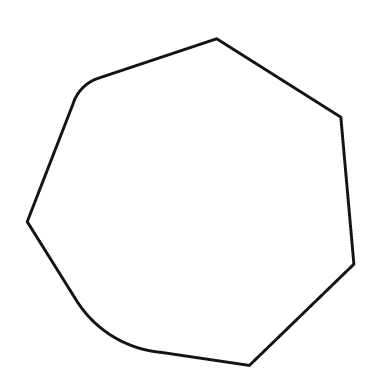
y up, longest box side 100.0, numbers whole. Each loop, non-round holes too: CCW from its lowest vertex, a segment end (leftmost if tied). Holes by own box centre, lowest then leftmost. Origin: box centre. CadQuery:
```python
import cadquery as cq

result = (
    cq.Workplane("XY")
    .moveTo(18.0, -50.0)
    .lineTo(50.0, -19.0)
    .lineTo(46.0, 26.0)
    .lineTo(8.0, 50.0)
    .lineTo(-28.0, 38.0)
    .threePointArc((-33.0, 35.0), (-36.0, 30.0))
    .lineTo(-50.0, -6.0)
    .lineTo(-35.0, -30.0)
    .threePointArc((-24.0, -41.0), (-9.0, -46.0))
    .close()
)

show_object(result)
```